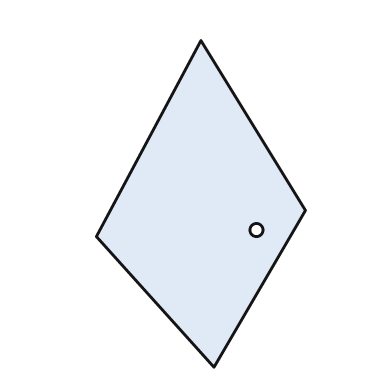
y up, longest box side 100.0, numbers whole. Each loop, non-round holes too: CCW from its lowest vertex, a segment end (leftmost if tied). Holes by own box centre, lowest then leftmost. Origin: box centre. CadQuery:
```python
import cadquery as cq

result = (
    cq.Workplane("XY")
    .moveTo(4.0, -50.0)
    .lineTo(32.0, -2.0)
    .lineTo(0.0, 50.0)
    .lineTo(-32.0, -10.0)
    .close()
    .moveTo(17.0, -8.0)
    .circle(2.0)
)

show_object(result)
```